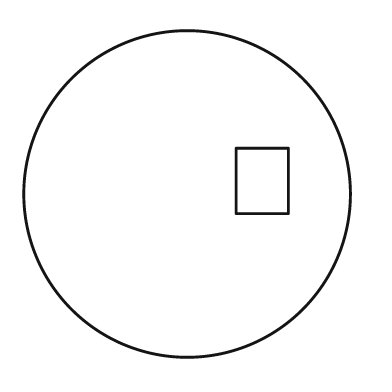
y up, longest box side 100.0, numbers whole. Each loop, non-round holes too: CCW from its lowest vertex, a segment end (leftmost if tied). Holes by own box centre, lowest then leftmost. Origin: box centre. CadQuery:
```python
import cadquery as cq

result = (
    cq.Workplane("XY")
    .moveTo(0.0, 0.0)
    .circle(50.0)
    .moveTo(15.0, -6.0)
    .lineTo(31.0, -6.0)
    .lineTo(31.0, 14.0)
    .lineTo(15.0, 14.0)
    .close()
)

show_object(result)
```